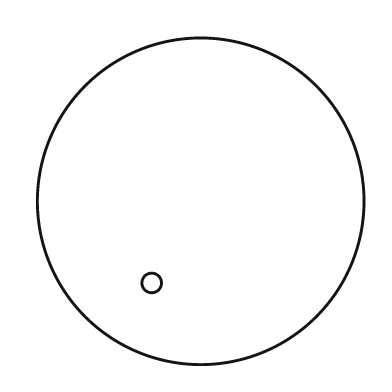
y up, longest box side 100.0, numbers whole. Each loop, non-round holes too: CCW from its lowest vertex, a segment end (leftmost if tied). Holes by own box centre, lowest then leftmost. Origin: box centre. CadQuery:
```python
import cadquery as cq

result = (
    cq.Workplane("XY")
    .moveTo(0.0, 0.0)
    .circle(50.0)
    .moveTo(-15.0, -25.0)
    .circle(3.0)
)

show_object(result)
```